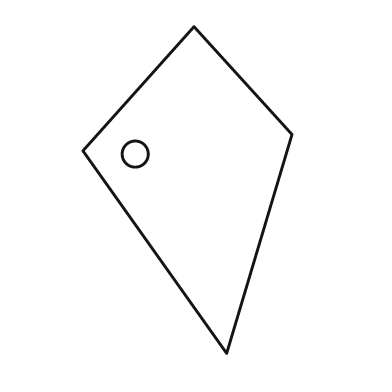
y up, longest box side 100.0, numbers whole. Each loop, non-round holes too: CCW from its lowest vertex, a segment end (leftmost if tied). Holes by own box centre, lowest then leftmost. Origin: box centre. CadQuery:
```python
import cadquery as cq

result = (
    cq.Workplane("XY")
    .moveTo(12.0, -50.0)
    .lineTo(32.0, 17.0)
    .lineTo(2.0, 50.0)
    .lineTo(-32.0, 12.0)
    .close()
    .moveTo(-16.0, 11.0)
    .circle(4.0)
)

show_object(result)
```